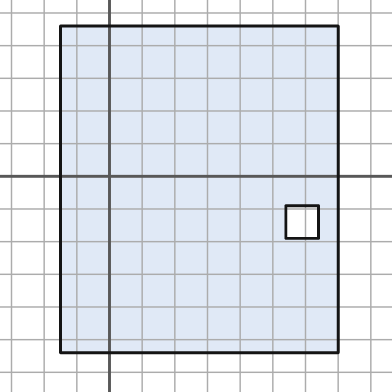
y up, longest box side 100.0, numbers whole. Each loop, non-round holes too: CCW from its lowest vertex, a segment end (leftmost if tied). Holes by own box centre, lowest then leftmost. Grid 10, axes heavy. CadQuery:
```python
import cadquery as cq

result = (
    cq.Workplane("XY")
    .moveTo(-15.0, -54.0)
    .lineTo(70.0, -54.0)
    .lineTo(70.0, 46.0)
    .lineTo(-15.0, 46.0)
    .close()
    .moveTo(54.0, -19.0)
    .lineTo(64.0, -19.0)
    .lineTo(64.0, -9.0)
    .lineTo(54.0, -9.0)
    .close()
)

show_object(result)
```